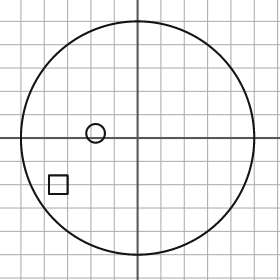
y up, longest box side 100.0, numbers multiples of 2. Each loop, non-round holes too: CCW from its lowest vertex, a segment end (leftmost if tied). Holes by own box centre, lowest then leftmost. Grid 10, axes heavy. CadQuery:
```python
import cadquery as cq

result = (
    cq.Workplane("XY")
    .moveTo(0.0, 0.0)
    .circle(50.0)
    .moveTo(-38.0, -24.0)
    .lineTo(-30.0, -24.0)
    .lineTo(-30.0, -16.0)
    .lineTo(-38.0, -16.0)
    .close()
    .moveTo(-18.0, 2.0)
    .circle(4.0)
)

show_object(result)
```